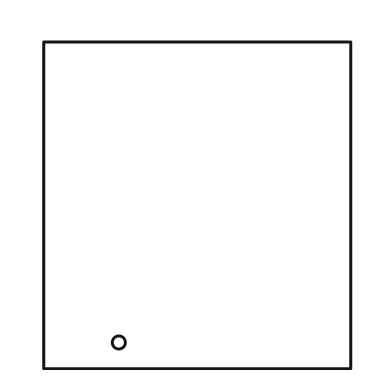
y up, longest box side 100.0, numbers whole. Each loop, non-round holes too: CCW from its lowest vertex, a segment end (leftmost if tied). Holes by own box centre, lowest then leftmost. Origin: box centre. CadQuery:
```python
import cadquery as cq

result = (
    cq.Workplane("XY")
    .moveTo(-47.0, -50.0)
    .lineTo(47.0, -50.0)
    .lineTo(47.0, 50.0)
    .lineTo(-47.0, 50.0)
    .close()
    .moveTo(-24.0, -42.0)
    .circle(2.0)
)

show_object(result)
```